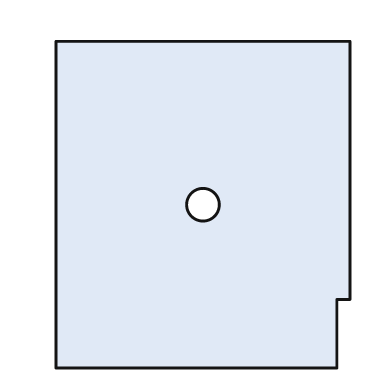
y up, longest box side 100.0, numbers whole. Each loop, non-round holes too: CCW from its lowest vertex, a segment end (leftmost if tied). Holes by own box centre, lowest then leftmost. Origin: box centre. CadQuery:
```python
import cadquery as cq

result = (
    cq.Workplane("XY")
    .moveTo(-45.0, -50.0)
    .lineTo(41.0, -50.0)
    .lineTo(41.0, -29.0)
    .lineTo(45.0, -29.0)
    .lineTo(45.0, 50.0)
    .lineTo(-45.0, 50.0)
    .close()
    .moveTo(0.0, 0.0)
    .circle(5.0)
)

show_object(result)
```